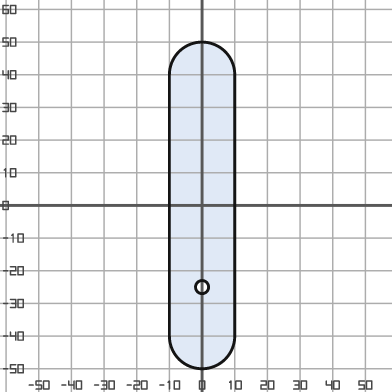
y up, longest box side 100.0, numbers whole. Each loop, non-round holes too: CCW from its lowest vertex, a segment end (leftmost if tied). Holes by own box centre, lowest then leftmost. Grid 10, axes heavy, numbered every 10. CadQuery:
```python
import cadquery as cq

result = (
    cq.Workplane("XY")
    .moveTo(-10.0, -40.0)
    .threePointArc((0.0, -50.0), (10.0, -40.0))
    .lineTo(10.0, 40.0)
    .threePointArc((0.0, 50.0), (-10.0, 40.0))
    .close()
    .moveTo(0.0, -25.0)
    .circle(2.0)
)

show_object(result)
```